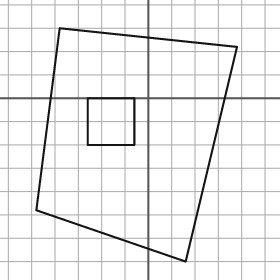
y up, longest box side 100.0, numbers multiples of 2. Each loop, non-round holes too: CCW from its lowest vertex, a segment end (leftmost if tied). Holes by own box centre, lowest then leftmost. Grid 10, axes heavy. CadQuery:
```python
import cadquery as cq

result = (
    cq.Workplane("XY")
    .moveTo(16.0, -70.0)
    .lineTo(38.0, 22.0)
    .lineTo(-38.0, 30.0)
    .lineTo(-48.0, -48.0)
    .close()
    .moveTo(-26.0, -20.0)
    .lineTo(-6.0, -20.0)
    .lineTo(-6.0, 0.0)
    .lineTo(-26.0, 0.0)
    .close()
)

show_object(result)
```